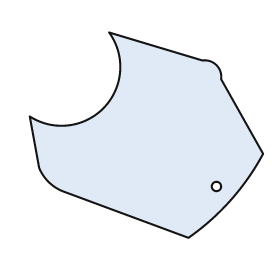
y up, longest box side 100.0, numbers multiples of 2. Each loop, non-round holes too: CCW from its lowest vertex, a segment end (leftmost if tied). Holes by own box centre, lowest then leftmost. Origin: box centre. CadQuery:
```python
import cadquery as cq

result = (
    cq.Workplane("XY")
    .moveTo(18.0, -44.0)
    .threePointArc((36.0, -28.0), (50.0, -8.0))
    .lineTo(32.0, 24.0)
    .threePointArc((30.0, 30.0), (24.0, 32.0))
    .lineTo(-16.0, 44.0)
    .threePointArc((-18.0, 12.0), (-50.0, 8.0))
    .lineTo(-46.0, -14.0)
    .threePointArc((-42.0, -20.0), (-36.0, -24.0))
    .close()
    .moveTo(30.0, -22.0)
    .circle(2.0)
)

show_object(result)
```